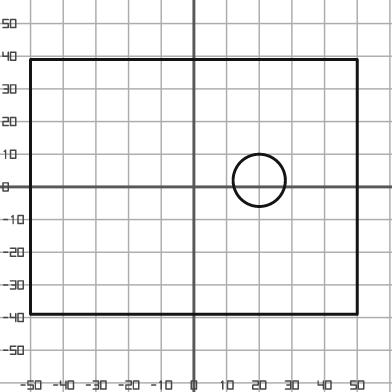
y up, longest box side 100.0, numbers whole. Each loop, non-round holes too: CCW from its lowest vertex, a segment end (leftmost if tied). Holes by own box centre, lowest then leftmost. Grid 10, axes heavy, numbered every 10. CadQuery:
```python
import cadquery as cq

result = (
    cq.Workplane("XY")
    .moveTo(-50.0, -39.0)
    .lineTo(50.0, -39.0)
    .lineTo(50.0, 39.0)
    .lineTo(-50.0, 39.0)
    .close()
    .moveTo(20.0, 2.0)
    .circle(8.0)
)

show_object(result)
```